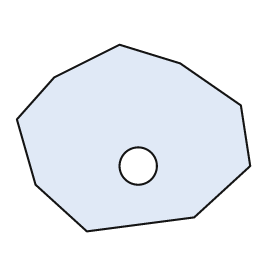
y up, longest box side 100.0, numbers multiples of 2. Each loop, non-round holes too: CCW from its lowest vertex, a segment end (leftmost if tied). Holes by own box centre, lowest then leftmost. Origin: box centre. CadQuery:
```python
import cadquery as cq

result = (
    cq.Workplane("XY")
    .moveTo(-20.0, -40.0)
    .lineTo(26.0, -34.0)
    .lineTo(50.0, -12.0)
    .lineTo(46.0, 14.0)
    .lineTo(20.0, 32.0)
    .lineTo(-6.0, 40.0)
    .lineTo(-34.0, 26.0)
    .lineTo(-50.0, 8.0)
    .lineTo(-42.0, -20.0)
    .close()
    .moveTo(2.0, -12.0)
    .circle(8.0)
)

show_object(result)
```